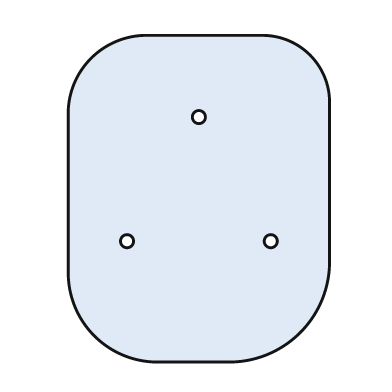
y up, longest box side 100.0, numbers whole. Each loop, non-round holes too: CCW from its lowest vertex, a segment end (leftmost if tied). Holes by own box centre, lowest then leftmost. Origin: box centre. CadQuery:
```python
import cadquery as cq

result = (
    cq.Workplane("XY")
    .moveTo(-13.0, -50.0)
    .lineTo(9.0, -50.0)
    .threePointArc((31.0, -41.0), (40.0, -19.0))
    .lineTo(40.0, 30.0)
    .threePointArc((34.0, 44.0), (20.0, 50.0))
    .lineTo(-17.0, 50.0)
    .threePointArc((-33.0, 43.0), (-40.0, 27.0))
    .lineTo(-40.0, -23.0)
    .threePointArc((-32.0, -42.0), (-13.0, -50.0))
    .close()
    .moveTo(-22.0, -13.0)
    .circle(2.0)
    .moveTo(22.0, -13.0)
    .circle(2.0)
    .moveTo(0.0, 25.0)
    .circle(2.0)
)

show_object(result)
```